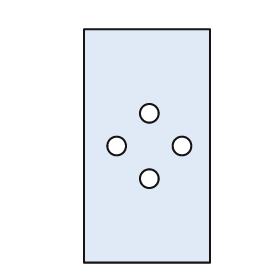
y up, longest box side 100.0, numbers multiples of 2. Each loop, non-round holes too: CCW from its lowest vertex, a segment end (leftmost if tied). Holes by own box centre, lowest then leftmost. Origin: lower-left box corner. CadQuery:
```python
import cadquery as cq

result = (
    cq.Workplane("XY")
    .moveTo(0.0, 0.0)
    .lineTo(54.0, 0.0)
    .lineTo(54.0, 100.0)
    .lineTo(0.0, 100.0)
    .close()
    .moveTo(28.0, 36.0)
    .circle(4.0)
    .moveTo(14.0, 50.0)
    .circle(4.0)
    .moveTo(42.0, 50.0)
    .circle(4.0)
    .moveTo(28.0, 64.0)
    .circle(4.0)
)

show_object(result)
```